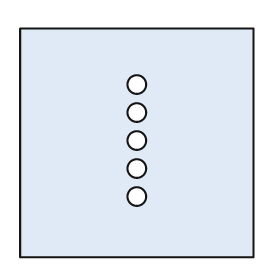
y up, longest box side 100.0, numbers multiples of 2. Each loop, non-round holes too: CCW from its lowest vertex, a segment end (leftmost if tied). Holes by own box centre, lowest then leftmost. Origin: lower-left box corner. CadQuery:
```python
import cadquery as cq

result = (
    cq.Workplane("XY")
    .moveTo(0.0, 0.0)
    .lineTo(100.0, 0.0)
    .lineTo(100.0, 98.0)
    .lineTo(0.0, 98.0)
    .close()
    .moveTo(50.0, 26.0)
    .circle(4.0)
    .moveTo(50.0, 38.0)
    .circle(4.0)
    .moveTo(50.0, 50.0)
    .circle(4.0)
    .moveTo(50.0, 62.0)
    .circle(4.0)
    .moveTo(50.0, 74.0)
    .circle(4.0)
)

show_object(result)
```